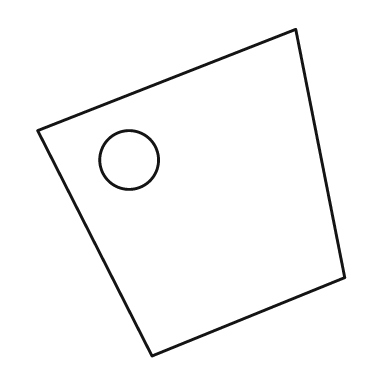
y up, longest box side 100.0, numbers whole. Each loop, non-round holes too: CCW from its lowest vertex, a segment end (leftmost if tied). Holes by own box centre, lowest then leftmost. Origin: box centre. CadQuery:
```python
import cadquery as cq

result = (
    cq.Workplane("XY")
    .moveTo(-12.0, -50.0)
    .lineTo(47.0, -26.0)
    .lineTo(32.0, 50.0)
    .lineTo(-47.0, 19.0)
    .close()
    .moveTo(-19.0, 10.0)
    .circle(9.0)
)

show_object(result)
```